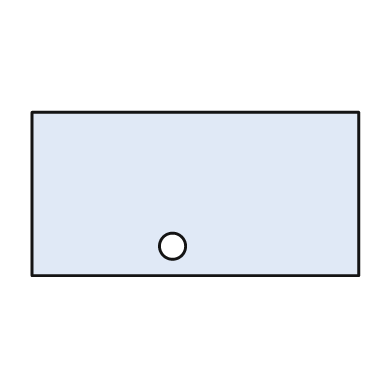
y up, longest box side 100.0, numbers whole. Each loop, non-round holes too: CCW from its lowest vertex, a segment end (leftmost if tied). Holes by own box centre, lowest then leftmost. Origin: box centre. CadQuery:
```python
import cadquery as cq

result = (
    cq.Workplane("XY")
    .moveTo(-50.0, -25.0)
    .lineTo(50.0, -25.0)
    .lineTo(50.0, 25.0)
    .lineTo(-50.0, 25.0)
    .close()
    .moveTo(-7.0, -16.0)
    .circle(4.0)
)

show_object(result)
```